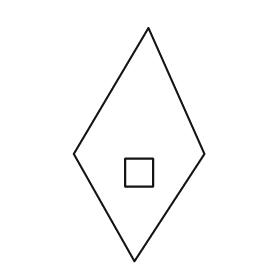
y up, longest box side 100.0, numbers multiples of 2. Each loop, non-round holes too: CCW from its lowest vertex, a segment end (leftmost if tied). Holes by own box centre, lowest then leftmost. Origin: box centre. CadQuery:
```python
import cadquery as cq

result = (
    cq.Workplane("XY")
    .moveTo(-2.0, -50.0)
    .lineTo(28.0, -4.0)
    .lineTo(4.0, 50.0)
    .lineTo(-28.0, -4.0)
    .close()
    .moveTo(-6.0, -18.0)
    .lineTo(6.0, -18.0)
    .lineTo(6.0, -6.0)
    .lineTo(-6.0, -6.0)
    .close()
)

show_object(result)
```